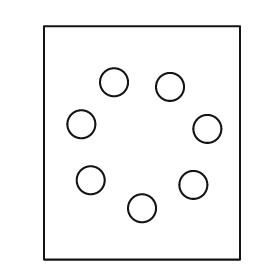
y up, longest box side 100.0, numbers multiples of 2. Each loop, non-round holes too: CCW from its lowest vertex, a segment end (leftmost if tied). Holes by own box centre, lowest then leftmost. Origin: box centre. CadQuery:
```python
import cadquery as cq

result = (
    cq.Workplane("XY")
    .moveTo(-42.0, -50.0)
    .lineTo(42.0, -50.0)
    .lineTo(42.0, 50.0)
    .lineTo(-42.0, 50.0)
    .close()
    .moveTo(0.0, -28.0)
    .circle(6.0)
    .moveTo(22.0, -18.0)
    .circle(6.0)
    .moveTo(-22.0, -16.0)
    .circle(6.0)
    .moveTo(28.0, 6.0)
    .circle(6.0)
    .moveTo(-26.0, 8.0)
    .circle(6.0)
    .moveTo(12.0, 24.0)
    .circle(6.0)
    .moveTo(-12.0, 26.0)
    .circle(6.0)
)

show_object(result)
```